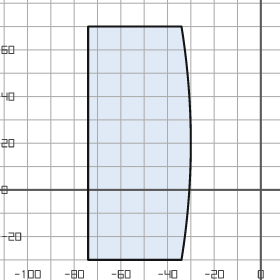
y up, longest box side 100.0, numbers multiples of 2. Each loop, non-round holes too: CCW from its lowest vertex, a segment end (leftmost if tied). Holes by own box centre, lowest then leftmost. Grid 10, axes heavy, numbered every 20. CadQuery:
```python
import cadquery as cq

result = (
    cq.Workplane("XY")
    .moveTo(-74.0, -30.0)
    .lineTo(-34.0, -30.0)
    .threePointArc((-30.0, 20.0), (-34.0, 70.0))
    .lineTo(-74.0, 70.0)
    .close()
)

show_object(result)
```